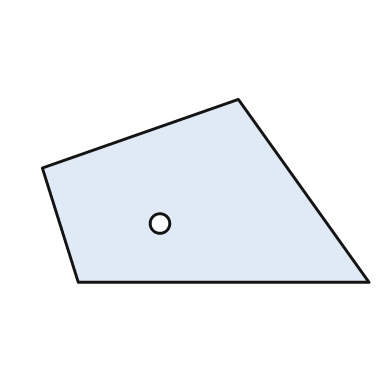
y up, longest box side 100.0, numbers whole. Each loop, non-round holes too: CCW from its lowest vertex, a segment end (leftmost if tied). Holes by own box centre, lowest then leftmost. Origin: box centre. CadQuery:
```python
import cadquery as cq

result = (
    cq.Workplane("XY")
    .moveTo(-39.0, -28.0)
    .lineTo(50.0, -28.0)
    .lineTo(10.0, 28.0)
    .lineTo(-50.0, 7.0)
    .close()
    .moveTo(-14.0, -10.0)
    .circle(3.0)
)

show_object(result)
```